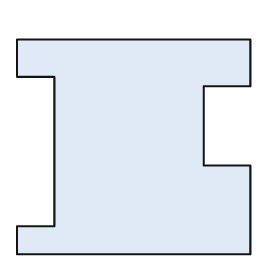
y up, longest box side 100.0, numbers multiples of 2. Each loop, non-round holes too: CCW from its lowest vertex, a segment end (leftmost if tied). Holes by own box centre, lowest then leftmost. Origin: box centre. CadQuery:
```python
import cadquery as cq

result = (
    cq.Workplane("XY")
    .moveTo(-50.0, -46.0)
    .lineTo(50.0, -46.0)
    .lineTo(50.0, -8.0)
    .lineTo(30.0, -8.0)
    .lineTo(30.0, 26.0)
    .lineTo(50.0, 26.0)
    .lineTo(50.0, 46.0)
    .lineTo(-50.0, 46.0)
    .lineTo(-50.0, 30.0)
    .lineTo(-34.0, 30.0)
    .lineTo(-34.0, -34.0)
    .lineTo(-50.0, -34.0)
    .close()
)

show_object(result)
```